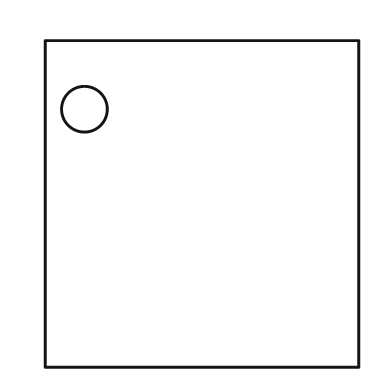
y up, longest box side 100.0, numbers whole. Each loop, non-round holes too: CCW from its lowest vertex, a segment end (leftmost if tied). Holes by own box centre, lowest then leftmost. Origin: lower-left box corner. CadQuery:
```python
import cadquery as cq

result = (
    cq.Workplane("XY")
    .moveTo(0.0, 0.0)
    .lineTo(96.0, 0.0)
    .lineTo(96.0, 100.0)
    .lineTo(0.0, 100.0)
    .close()
    .moveTo(12.0, 79.0)
    .circle(7.0)
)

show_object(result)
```